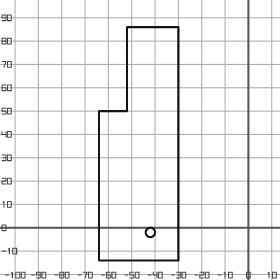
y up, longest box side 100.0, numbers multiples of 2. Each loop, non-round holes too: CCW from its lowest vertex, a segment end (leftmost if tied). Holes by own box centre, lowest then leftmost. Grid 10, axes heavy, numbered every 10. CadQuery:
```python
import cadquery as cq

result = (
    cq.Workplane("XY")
    .moveTo(-64.0, -14.0)
    .lineTo(-30.0, -14.0)
    .lineTo(-30.0, 86.0)
    .lineTo(-52.0, 86.0)
    .lineTo(-52.0, 50.0)
    .lineTo(-64.0, 50.0)
    .close()
    .moveTo(-42.0, -2.0)
    .circle(2.0)
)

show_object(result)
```